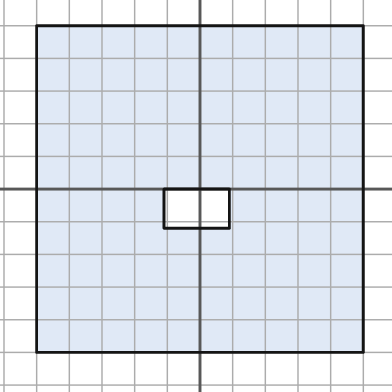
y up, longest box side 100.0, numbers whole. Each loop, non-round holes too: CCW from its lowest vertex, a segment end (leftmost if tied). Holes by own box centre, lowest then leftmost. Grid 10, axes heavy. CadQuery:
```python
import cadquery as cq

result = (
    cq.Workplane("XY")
    .moveTo(-50.0, -50.0)
    .lineTo(50.0, -50.0)
    .lineTo(50.0, 50.0)
    .lineTo(-50.0, 50.0)
    .close()
    .moveTo(-11.0, -12.0)
    .lineTo(9.0, -12.0)
    .lineTo(9.0, 0.0)
    .lineTo(-11.0, 0.0)
    .close()
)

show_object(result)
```